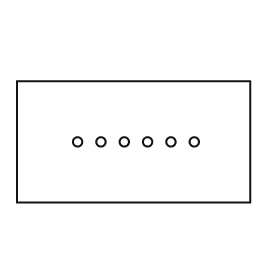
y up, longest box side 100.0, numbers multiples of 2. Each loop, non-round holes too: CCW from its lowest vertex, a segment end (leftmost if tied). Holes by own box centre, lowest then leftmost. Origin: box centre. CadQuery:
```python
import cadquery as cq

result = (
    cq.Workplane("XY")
    .moveTo(-50.0, -26.0)
    .lineTo(50.0, -26.0)
    .lineTo(50.0, 26.0)
    .lineTo(-50.0, 26.0)
    .close()
    .moveTo(-24.0, 0.0)
    .circle(2.0)
    .moveTo(-14.0, 0.0)
    .circle(2.0)
    .moveTo(-4.0, 0.0)
    .circle(2.0)
    .moveTo(6.0, 0.0)
    .circle(2.0)
    .moveTo(16.0, 0.0)
    .circle(2.0)
    .moveTo(26.0, 0.0)
    .circle(2.0)
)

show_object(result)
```